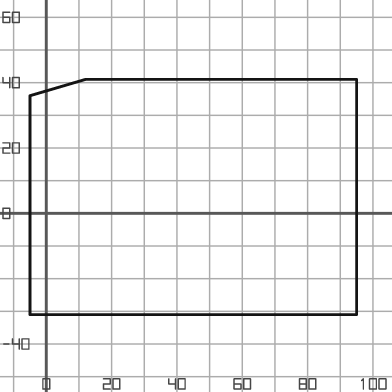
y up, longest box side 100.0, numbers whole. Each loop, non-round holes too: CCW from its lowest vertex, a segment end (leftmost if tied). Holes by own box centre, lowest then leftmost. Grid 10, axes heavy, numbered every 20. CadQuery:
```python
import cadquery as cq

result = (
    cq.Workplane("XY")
    .moveTo(-5.0, -31.0)
    .lineTo(95.0, -31.0)
    .lineTo(95.0, 41.0)
    .lineTo(12.0, 41.0)
    .lineTo(-5.0, 36.0)
    .close()
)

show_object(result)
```